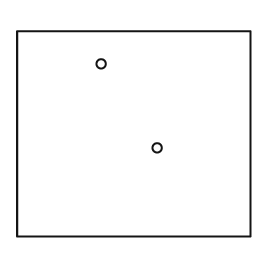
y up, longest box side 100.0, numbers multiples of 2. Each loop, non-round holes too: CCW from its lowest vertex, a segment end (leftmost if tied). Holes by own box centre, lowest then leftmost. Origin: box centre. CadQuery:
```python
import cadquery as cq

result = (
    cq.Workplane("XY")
    .moveTo(-50.0, -44.0)
    .lineTo(50.0, -44.0)
    .lineTo(50.0, 44.0)
    .lineTo(-50.0, 44.0)
    .close()
    .moveTo(10.0, -6.0)
    .circle(2.0)
    .moveTo(-14.0, 30.0)
    .circle(2.0)
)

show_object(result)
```